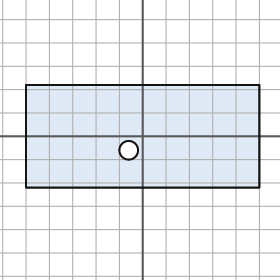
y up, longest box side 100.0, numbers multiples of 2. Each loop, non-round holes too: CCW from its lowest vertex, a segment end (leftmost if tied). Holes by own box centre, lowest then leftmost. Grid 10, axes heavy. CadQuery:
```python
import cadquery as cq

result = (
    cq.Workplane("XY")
    .moveTo(-50.0, -22.0)
    .lineTo(50.0, -22.0)
    .lineTo(50.0, 22.0)
    .lineTo(-50.0, 22.0)
    .close()
    .moveTo(-6.0, -6.0)
    .circle(4.0)
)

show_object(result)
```